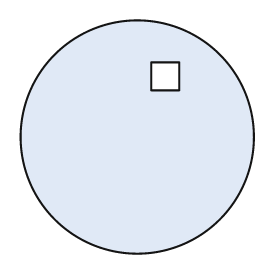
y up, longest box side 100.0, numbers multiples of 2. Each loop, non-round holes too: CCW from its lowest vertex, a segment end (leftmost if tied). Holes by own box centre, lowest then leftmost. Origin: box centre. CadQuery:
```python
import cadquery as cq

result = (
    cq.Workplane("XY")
    .moveTo(0.0, 0.0)
    .circle(50.0)
    .moveTo(6.0, 20.0)
    .lineTo(18.0, 20.0)
    .lineTo(18.0, 32.0)
    .lineTo(6.0, 32.0)
    .close()
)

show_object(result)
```